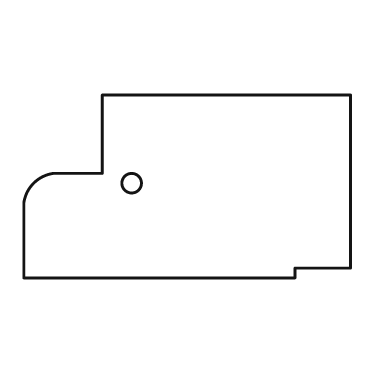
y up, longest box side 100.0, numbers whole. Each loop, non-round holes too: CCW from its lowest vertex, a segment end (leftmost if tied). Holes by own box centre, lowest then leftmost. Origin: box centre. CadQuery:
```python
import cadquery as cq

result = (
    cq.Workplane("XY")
    .moveTo(-50.0, -28.0)
    .lineTo(33.0, -28.0)
    .lineTo(33.0, -25.0)
    .lineTo(50.0, -25.0)
    .lineTo(50.0, 28.0)
    .lineTo(-26.0, 28.0)
    .lineTo(-26.0, 4.0)
    .lineTo(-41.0, 4.0)
    .threePointArc((-47.0, 1.0), (-50.0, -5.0))
    .close()
    .moveTo(-17.0, 1.0)
    .circle(3.0)
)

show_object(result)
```